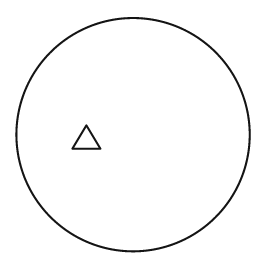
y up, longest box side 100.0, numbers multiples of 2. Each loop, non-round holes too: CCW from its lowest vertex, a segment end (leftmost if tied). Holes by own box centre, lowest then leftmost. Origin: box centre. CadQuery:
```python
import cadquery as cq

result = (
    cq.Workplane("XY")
    .moveTo(0.0, 0.0)
    .circle(50.0)
    .moveTo(-26.0, -6.0)
    .lineTo(-14.0, -6.0)
    .lineTo(-20.0, 4.0)
    .close()
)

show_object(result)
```